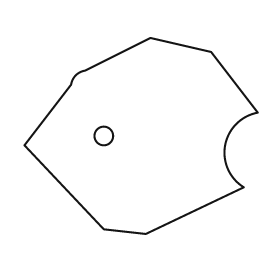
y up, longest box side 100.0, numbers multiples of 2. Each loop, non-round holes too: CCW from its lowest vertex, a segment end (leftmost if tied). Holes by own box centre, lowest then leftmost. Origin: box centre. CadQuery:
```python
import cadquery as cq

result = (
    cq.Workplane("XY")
    .moveTo(2.0, -42.0)
    .lineTo(44.0, -22.0)
    .threePointArc((36.0, -4.0), (50.0, 10.0))
    .lineTo(30.0, 36.0)
    .lineTo(4.0, 42.0)
    .lineTo(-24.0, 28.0)
    .threePointArc((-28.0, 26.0), (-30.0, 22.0))
    .lineTo(-50.0, -4.0)
    .lineTo(-16.0, -40.0)
    .close()
    .moveTo(-16.0, 0.0)
    .circle(4.0)
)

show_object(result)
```